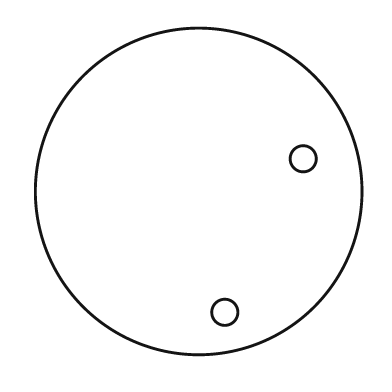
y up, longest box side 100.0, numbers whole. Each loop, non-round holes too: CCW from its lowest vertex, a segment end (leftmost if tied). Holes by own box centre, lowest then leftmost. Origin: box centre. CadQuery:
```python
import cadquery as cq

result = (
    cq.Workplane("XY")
    .moveTo(0.0, 0.0)
    .circle(50.0)
    .moveTo(8.0, -37.0)
    .circle(4.0)
    .moveTo(32.0, 10.0)
    .circle(4.0)
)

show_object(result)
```